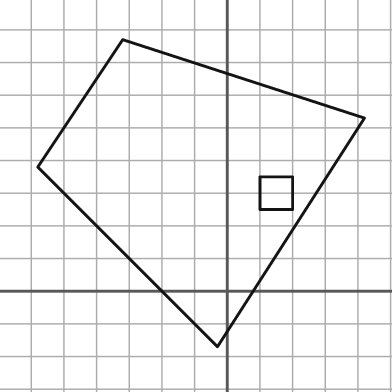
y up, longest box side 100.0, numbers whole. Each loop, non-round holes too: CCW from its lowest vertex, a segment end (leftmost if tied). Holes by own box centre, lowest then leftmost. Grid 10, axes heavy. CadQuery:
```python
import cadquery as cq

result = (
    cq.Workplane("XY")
    .moveTo(-3.0, -17.0)
    .lineTo(42.0, 53.0)
    .lineTo(-32.0, 77.0)
    .lineTo(-58.0, 38.0)
    .close()
    .moveTo(10.0, 25.0)
    .lineTo(20.0, 25.0)
    .lineTo(20.0, 35.0)
    .lineTo(10.0, 35.0)
    .close()
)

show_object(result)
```